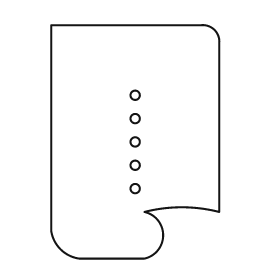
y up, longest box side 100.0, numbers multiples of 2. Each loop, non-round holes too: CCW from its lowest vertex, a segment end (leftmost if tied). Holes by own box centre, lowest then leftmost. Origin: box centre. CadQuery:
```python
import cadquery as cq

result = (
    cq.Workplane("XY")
    .moveTo(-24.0, -50.0)
    .lineTo(4.0, -50.0)
    .threePointArc((12.0, -40.0), (4.0, -30.0))
    .threePointArc((20.0, -28.0), (36.0, -30.0))
    .lineTo(36.0, 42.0)
    .threePointArc((34.0, 48.0), (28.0, 50.0))
    .lineTo(-36.0, 50.0)
    .lineTo(-36.0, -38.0)
    .threePointArc((-32.0, -46.0), (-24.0, -50.0))
    .close()
    .moveTo(0.0, -20.0)
    .circle(2.0)
    .moveTo(0.0, -10.0)
    .circle(2.0)
    .moveTo(0.0, 0.0)
    .circle(2.0)
    .moveTo(0.0, 10.0)
    .circle(2.0)
    .moveTo(0.0, 20.0)
    .circle(2.0)
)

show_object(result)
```